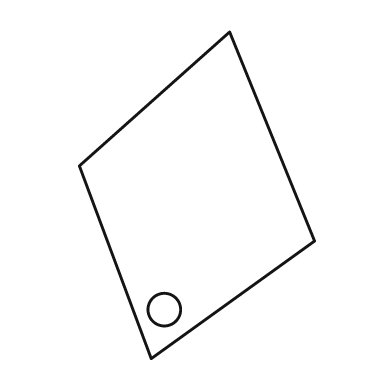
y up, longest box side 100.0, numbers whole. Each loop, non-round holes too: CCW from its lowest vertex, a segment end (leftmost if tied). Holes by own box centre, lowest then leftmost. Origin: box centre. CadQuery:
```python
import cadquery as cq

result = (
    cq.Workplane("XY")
    .moveTo(-14.0, -50.0)
    .lineTo(36.0, -14.0)
    .lineTo(10.0, 50.0)
    .lineTo(-36.0, 9.0)
    .close()
    .moveTo(-10.0, -35.0)
    .circle(5.0)
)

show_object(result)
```